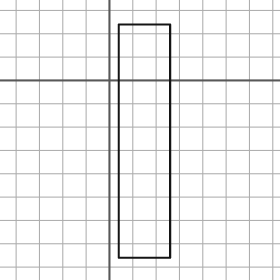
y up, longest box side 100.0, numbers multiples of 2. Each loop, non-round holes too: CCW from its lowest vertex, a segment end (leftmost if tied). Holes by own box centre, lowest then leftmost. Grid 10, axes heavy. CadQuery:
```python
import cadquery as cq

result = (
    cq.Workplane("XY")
    .moveTo(4.0, -76.0)
    .lineTo(26.0, -76.0)
    .lineTo(26.0, 24.0)
    .lineTo(4.0, 24.0)
    .close()
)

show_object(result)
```